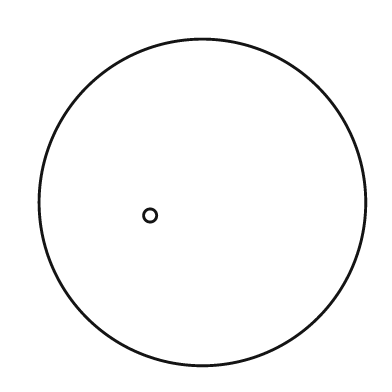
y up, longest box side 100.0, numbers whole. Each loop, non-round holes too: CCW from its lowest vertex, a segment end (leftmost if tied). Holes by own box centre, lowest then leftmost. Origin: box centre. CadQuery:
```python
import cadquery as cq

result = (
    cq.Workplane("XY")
    .moveTo(0.0, 0.0)
    .circle(50.0)
    .moveTo(-16.0, -4.0)
    .circle(2.0)
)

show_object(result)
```